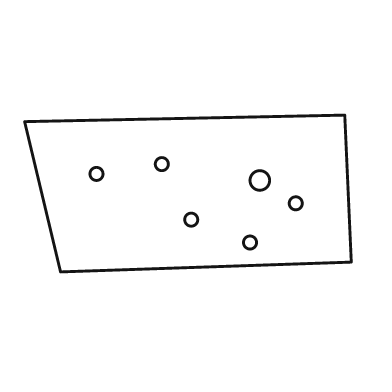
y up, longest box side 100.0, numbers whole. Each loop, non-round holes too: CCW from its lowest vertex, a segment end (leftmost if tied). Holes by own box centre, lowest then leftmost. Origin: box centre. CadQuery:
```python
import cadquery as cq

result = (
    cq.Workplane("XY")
    .moveTo(-39.0, -24.0)
    .lineTo(50.0, -21.0)
    .lineTo(48.0, 24.0)
    .lineTo(-50.0, 22.0)
    .close()
    .moveTo(19.0, -15.0)
    .circle(2.0)
    .moveTo(1.0, -8.0)
    .circle(2.0)
    .moveTo(33.0, -3.0)
    .circle(2.0)
    .moveTo(22.0, 4.0)
    .circle(3.0)
    .moveTo(-28.0, 6.0)
    .circle(2.0)
    .moveTo(-8.0, 9.0)
    .circle(2.0)
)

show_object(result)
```